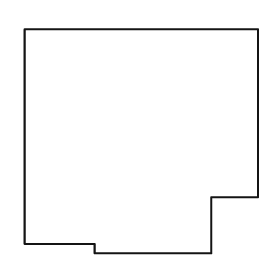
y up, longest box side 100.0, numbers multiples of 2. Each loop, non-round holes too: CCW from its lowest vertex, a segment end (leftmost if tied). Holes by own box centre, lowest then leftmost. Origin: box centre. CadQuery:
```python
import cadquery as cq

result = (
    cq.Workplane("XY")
    .moveTo(-20.0, -48.0)
    .lineTo(30.0, -48.0)
    .lineTo(30.0, -24.0)
    .lineTo(50.0, -24.0)
    .lineTo(50.0, 48.0)
    .lineTo(-50.0, 48.0)
    .lineTo(-50.0, -44.0)
    .lineTo(-20.0, -44.0)
    .close()
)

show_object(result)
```